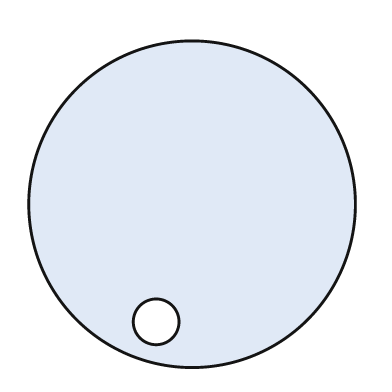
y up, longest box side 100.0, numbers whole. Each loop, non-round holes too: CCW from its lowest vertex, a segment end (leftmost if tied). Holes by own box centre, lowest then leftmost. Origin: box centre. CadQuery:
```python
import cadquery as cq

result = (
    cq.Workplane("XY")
    .moveTo(0.0, 0.0)
    .circle(50.0)
    .moveTo(-11.0, -36.0)
    .circle(7.0)
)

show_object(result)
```